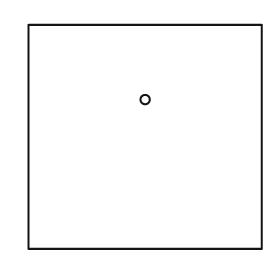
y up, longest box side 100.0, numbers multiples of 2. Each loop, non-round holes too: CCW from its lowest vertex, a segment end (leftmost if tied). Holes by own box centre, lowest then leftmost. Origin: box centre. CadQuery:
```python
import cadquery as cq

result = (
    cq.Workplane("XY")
    .moveTo(-50.0, -48.0)
    .lineTo(50.0, -48.0)
    .lineTo(50.0, 48.0)
    .lineTo(-50.0, 48.0)
    .close()
    .moveTo(0.0, 16.0)
    .circle(2.0)
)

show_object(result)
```